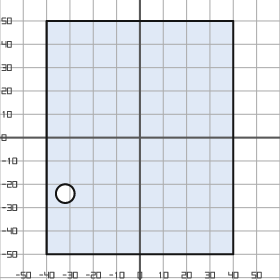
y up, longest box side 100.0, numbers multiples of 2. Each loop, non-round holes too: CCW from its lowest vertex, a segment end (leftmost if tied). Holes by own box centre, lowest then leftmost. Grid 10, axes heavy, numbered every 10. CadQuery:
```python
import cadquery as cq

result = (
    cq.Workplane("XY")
    .moveTo(-40.0, -50.0)
    .lineTo(40.0, -50.0)
    .lineTo(40.0, 50.0)
    .lineTo(-40.0, 50.0)
    .close()
    .moveTo(-32.0, -24.0)
    .circle(4.0)
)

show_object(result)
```